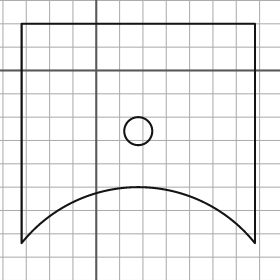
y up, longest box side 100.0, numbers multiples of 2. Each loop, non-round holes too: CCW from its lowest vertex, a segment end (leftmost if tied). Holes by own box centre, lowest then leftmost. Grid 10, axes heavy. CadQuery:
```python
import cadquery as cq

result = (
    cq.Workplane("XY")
    .moveTo(-32.0, -74.0)
    .threePointArc((18.0, -50.0), (68.0, -74.0))
    .lineTo(68.0, 20.0)
    .lineTo(-32.0, 20.0)
    .close()
    .moveTo(18.0, -26.0)
    .circle(6.0)
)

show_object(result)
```